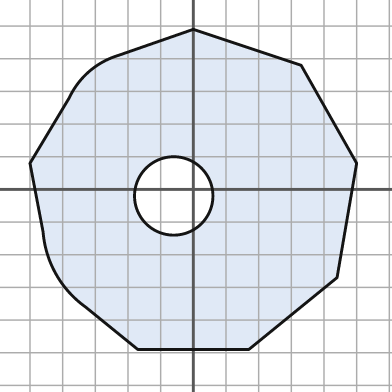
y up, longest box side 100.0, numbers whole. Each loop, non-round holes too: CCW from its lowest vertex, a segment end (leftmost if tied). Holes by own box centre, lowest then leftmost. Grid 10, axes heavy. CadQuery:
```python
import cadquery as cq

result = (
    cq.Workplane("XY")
    .moveTo(-17.0, -49.0)
    .lineTo(17.0, -49.0)
    .lineTo(44.0, -27.0)
    .lineTo(50.0, 8.0)
    .lineTo(33.0, 38.0)
    .lineTo(0.0, 49.0)
    .lineTo(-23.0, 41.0)
    .threePointArc((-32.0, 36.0), (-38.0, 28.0))
    .lineTo(-50.0, 8.0)
    .lineTo(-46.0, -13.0)
    .threePointArc((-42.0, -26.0), (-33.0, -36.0))
    .close()
    .moveTo(-6.0, -2.0)
    .circle(12.0)
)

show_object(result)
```